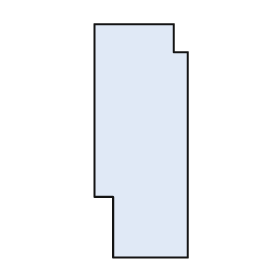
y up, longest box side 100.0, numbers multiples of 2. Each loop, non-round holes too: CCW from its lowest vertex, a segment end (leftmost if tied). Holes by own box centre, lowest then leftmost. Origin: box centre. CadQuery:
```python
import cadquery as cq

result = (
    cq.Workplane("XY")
    .moveTo(-12.0, -50.0)
    .lineTo(20.0, -50.0)
    .lineTo(20.0, 38.0)
    .lineTo(14.0, 38.0)
    .lineTo(14.0, 50.0)
    .lineTo(-20.0, 50.0)
    .lineTo(-20.0, -24.0)
    .lineTo(-12.0, -24.0)
    .close()
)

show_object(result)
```